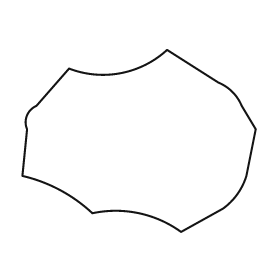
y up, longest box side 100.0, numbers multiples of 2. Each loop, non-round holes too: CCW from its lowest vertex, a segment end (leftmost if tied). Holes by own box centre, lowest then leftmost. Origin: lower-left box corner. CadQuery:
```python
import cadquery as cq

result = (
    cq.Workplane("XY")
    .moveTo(68.0, 0.0)
    .lineTo(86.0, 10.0)
    .threePointArc((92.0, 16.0), (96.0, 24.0))
    .lineTo(100.0, 44.0)
    .lineTo(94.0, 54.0)
    .threePointArc((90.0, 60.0), (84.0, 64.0))
    .lineTo(62.0, 78.0)
    .threePointArc((42.0, 68.0), (20.0, 70.0))
    .lineTo(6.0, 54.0)
    .threePointArc((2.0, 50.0), (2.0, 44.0))
    .lineTo(0.0, 24.0)
    .threePointArc((16.0, 18.0), (30.0, 8.0))
    .threePointArc((50.0, 8.0), (68.0, 0.0))
    .close()
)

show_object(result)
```